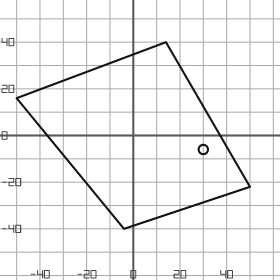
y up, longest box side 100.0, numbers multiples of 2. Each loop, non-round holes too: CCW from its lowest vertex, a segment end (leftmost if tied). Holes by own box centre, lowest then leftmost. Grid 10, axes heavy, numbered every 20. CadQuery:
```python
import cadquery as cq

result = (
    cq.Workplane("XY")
    .moveTo(-4.0, -40.0)
    .lineTo(50.0, -22.0)
    .lineTo(14.0, 40.0)
    .lineTo(-50.0, 16.0)
    .close()
    .moveTo(30.0, -6.0)
    .circle(2.0)
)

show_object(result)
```